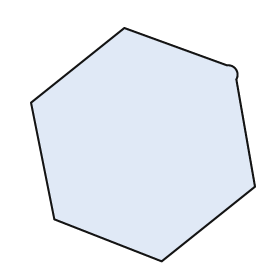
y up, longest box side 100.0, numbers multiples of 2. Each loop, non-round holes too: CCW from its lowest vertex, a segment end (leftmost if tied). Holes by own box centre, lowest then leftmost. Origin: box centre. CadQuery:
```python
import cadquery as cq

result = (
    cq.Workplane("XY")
    .moveTo(8.0, -50.0)
    .lineTo(48.0, -18.0)
    .lineTo(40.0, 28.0)
    .threePointArc((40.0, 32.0), (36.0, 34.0))
    .lineTo(-8.0, 50.0)
    .lineTo(-48.0, 18.0)
    .lineTo(-38.0, -32.0)
    .close()
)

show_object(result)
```